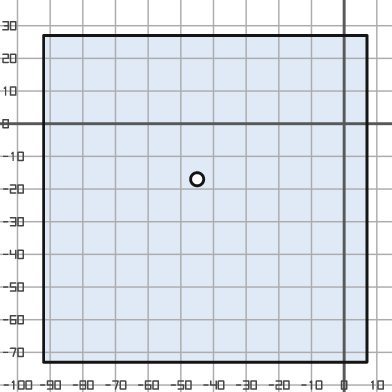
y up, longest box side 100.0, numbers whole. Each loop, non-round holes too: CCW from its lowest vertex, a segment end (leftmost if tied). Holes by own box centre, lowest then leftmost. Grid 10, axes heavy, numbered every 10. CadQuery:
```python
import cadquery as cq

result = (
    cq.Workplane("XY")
    .moveTo(-92.0, -73.0)
    .lineTo(7.0, -73.0)
    .lineTo(7.0, 27.0)
    .lineTo(-92.0, 27.0)
    .close()
    .moveTo(-45.0, -17.0)
    .circle(2.0)
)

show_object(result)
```